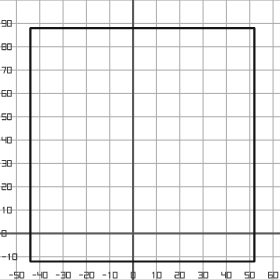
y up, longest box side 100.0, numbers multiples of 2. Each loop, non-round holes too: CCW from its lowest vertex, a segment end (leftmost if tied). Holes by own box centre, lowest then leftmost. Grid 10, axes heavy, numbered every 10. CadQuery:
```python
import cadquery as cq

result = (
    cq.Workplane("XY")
    .moveTo(-44.0, -12.0)
    .lineTo(52.0, -12.0)
    .lineTo(52.0, 88.0)
    .lineTo(-44.0, 88.0)
    .close()
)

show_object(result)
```